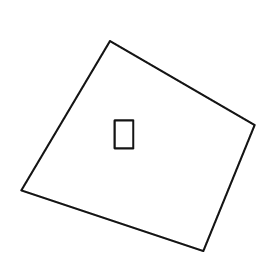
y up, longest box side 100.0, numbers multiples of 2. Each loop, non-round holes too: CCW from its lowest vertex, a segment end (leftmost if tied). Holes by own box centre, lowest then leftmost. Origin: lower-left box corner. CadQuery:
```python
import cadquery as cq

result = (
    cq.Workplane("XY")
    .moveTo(78.0, 0.0)
    .lineTo(100.0, 54.0)
    .lineTo(38.0, 90.0)
    .lineTo(0.0, 26.0)
    .close()
    .moveTo(40.0, 44.0)
    .lineTo(48.0, 44.0)
    .lineTo(48.0, 56.0)
    .lineTo(40.0, 56.0)
    .close()
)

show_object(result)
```